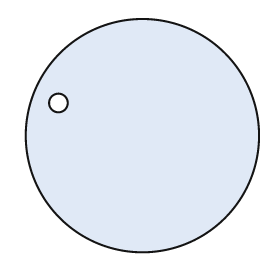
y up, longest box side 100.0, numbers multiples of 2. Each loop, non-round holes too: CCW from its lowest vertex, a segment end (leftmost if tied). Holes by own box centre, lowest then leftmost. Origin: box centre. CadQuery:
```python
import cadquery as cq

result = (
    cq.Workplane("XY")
    .moveTo(0.0, 0.0)
    .circle(50.0)
    .moveTo(-36.0, 14.0)
    .circle(4.0)
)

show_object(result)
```